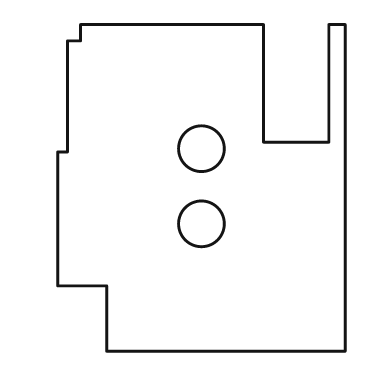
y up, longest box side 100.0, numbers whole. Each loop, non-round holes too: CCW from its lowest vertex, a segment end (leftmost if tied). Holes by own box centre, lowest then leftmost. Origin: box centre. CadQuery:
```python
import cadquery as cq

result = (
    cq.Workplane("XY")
    .moveTo(-29.0, -50.0)
    .lineTo(44.0, -50.0)
    .lineTo(44.0, 50.0)
    .lineTo(39.0, 50.0)
    .lineTo(39.0, 14.0)
    .lineTo(19.0, 14.0)
    .lineTo(19.0, 50.0)
    .lineTo(-37.0, 50.0)
    .lineTo(-37.0, 45.0)
    .lineTo(-41.0, 45.0)
    .lineTo(-41.0, 11.0)
    .lineTo(-44.0, 11.0)
    .lineTo(-44.0, -30.0)
    .lineTo(-29.0, -30.0)
    .close()
    .moveTo(0.0, -11.0)
    .circle(7.0)
    .moveTo(0.0, 12.0)
    .circle(7.0)
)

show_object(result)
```